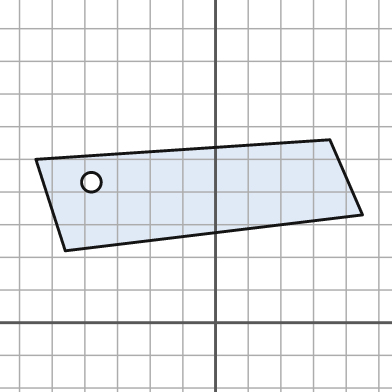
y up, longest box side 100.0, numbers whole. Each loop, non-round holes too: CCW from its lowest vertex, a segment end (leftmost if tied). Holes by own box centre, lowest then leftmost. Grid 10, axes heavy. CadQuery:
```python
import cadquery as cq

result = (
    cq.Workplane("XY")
    .moveTo(-46.0, 22.0)
    .lineTo(45.0, 33.0)
    .lineTo(35.0, 56.0)
    .lineTo(-55.0, 50.0)
    .close()
    .moveTo(-38.0, 43.0)
    .circle(3.0)
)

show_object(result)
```